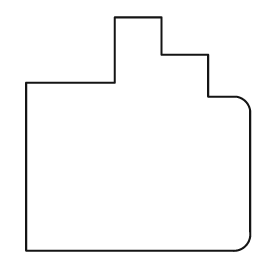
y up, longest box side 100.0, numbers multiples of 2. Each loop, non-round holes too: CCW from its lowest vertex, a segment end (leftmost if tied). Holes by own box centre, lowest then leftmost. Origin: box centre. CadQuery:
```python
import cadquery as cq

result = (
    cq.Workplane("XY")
    .moveTo(-48.0, -50.0)
    .lineTo(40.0, -50.0)
    .threePointArc((46.0, -48.0), (48.0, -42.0))
    .lineTo(48.0, 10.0)
    .threePointArc((46.0, 14.0), (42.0, 16.0))
    .lineTo(30.0, 16.0)
    .lineTo(30.0, 34.0)
    .lineTo(10.0, 34.0)
    .lineTo(10.0, 50.0)
    .lineTo(-10.0, 50.0)
    .lineTo(-10.0, 22.0)
    .lineTo(-48.0, 22.0)
    .close()
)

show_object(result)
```